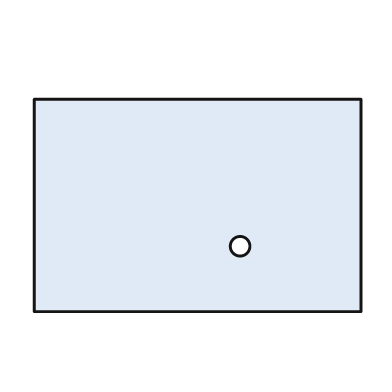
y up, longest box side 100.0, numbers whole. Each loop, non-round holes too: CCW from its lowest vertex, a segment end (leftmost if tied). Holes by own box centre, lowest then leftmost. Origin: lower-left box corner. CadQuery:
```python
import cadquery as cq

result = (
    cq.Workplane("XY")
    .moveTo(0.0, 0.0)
    .lineTo(100.0, 0.0)
    .lineTo(100.0, 65.0)
    .lineTo(0.0, 65.0)
    .close()
    .moveTo(63.0, 20.0)
    .circle(3.0)
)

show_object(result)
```